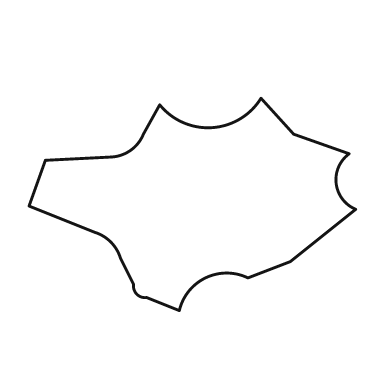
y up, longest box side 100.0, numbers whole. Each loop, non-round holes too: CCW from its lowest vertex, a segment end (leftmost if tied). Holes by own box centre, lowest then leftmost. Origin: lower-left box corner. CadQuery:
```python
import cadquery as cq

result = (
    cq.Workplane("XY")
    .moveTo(46.0, 0.0)
    .threePointArc((54.0, 10.0), (67.0, 10.0))
    .lineTo(80.0, 15.0)
    .lineTo(100.0, 31.0)
    .threePointArc((94.0, 39.0), (98.0, 48.0))
    .lineTo(81.0, 54.0)
    .lineTo(71.0, 65.0)
    .threePointArc((56.0, 56.0), (40.0, 63.0))
    .lineTo(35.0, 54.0)
    .threePointArc((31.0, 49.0), (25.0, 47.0))
    .lineTo(5.0, 46.0)
    .lineTo(0.0, 32.0)
    .lineTo(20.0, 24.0)
    .threePointArc((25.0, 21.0), (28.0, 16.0))
    .lineTo(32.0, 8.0)
    .threePointArc((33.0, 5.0), (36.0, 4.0))
    .close()
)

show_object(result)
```